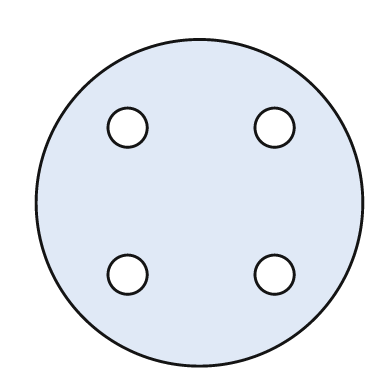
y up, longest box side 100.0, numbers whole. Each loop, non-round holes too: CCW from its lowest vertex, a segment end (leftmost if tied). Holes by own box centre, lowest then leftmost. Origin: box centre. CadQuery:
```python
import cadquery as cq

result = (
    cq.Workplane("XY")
    .moveTo(0.0, 0.0)
    .circle(50.0)
    .moveTo(-22.0, -22.0)
    .circle(6.0)
    .moveTo(23.0, -22.0)
    .circle(6.0)
    .moveTo(-22.0, 23.0)
    .circle(6.0)
    .moveTo(23.0, 23.0)
    .circle(6.0)
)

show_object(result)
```